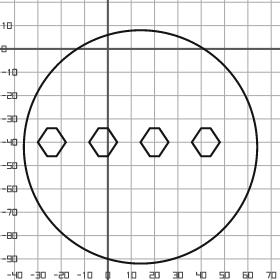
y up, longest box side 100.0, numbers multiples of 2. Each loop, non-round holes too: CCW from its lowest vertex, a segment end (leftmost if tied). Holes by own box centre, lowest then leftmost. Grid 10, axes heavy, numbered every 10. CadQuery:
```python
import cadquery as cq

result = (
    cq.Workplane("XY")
    .moveTo(14.0, -42.0)
    .circle(50.0)
    .moveTo(-26.0, -46.0)
    .lineTo(-22.0, -46.0)
    .lineTo(-18.0, -40.0)
    .lineTo(-22.0, -34.0)
    .lineTo(-26.0, -34.0)
    .lineTo(-30.0, -40.0)
    .close()
    .moveTo(-4.0, -46.0)
    .lineTo(0.0, -46.0)
    .lineTo(4.0, -40.0)
    .lineTo(0.0, -34.0)
    .lineTo(-4.0, -34.0)
    .lineTo(-8.0, -40.0)
    .close()
    .moveTo(18.0, -46.0)
    .lineTo(22.0, -46.0)
    .lineTo(26.0, -40.0)
    .lineTo(22.0, -34.0)
    .lineTo(18.0, -34.0)
    .lineTo(14.0, -40.0)
    .close()
    .moveTo(40.0, -46.0)
    .lineTo(44.0, -46.0)
    .lineTo(48.0, -40.0)
    .lineTo(44.0, -34.0)
    .lineTo(40.0, -34.0)
    .lineTo(36.0, -40.0)
    .close()
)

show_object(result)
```